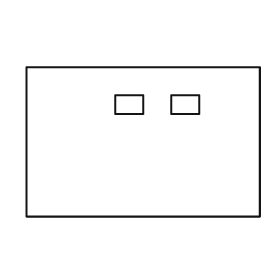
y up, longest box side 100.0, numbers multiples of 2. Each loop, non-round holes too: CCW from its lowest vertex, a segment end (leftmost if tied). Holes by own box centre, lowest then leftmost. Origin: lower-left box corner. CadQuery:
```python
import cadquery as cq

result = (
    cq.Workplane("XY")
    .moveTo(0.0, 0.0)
    .lineTo(100.0, 0.0)
    .lineTo(100.0, 64.0)
    .lineTo(0.0, 64.0)
    .close()
    .moveTo(38.0, 44.0)
    .lineTo(50.0, 44.0)
    .lineTo(50.0, 52.0)
    .lineTo(38.0, 52.0)
    .close()
    .moveTo(62.0, 44.0)
    .lineTo(74.0, 44.0)
    .lineTo(74.0, 52.0)
    .lineTo(62.0, 52.0)
    .close()
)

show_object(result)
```